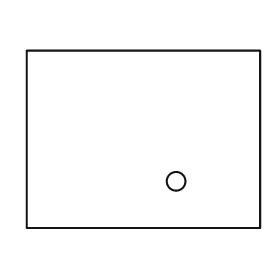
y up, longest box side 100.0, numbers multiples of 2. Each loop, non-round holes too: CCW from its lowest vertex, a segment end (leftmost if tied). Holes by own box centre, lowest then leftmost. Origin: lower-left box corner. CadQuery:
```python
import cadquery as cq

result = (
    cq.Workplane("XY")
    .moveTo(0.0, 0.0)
    .lineTo(100.0, 0.0)
    .lineTo(100.0, 76.0)
    .lineTo(0.0, 76.0)
    .close()
    .moveTo(64.0, 20.0)
    .circle(4.0)
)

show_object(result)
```